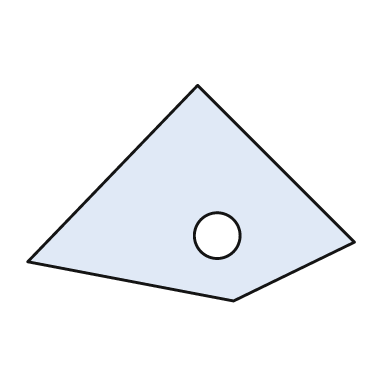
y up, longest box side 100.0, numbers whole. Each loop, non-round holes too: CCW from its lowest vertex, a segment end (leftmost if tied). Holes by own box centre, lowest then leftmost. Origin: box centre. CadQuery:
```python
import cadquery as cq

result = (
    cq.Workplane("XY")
    .moveTo(13.0, -33.0)
    .lineTo(50.0, -15.0)
    .lineTo(2.0, 33.0)
    .lineTo(-50.0, -21.0)
    .close()
    .moveTo(8.0, -13.0)
    .circle(7.0)
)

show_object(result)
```